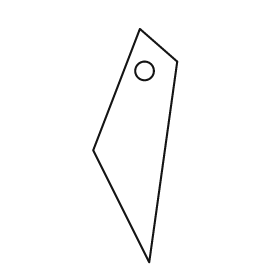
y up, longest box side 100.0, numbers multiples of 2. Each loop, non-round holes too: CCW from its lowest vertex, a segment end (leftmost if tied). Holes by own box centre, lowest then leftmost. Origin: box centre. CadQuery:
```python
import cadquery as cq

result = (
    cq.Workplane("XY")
    .moveTo(6.0, -50.0)
    .lineTo(18.0, 36.0)
    .lineTo(2.0, 50.0)
    .lineTo(-18.0, -2.0)
    .close()
    .moveTo(4.0, 32.0)
    .circle(4.0)
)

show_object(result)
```